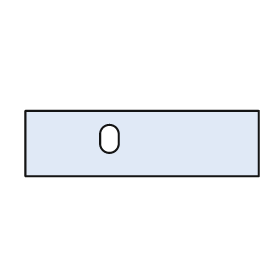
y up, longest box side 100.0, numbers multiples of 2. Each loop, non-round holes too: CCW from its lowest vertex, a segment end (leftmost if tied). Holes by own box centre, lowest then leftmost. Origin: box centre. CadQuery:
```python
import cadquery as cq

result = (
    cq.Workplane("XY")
    .moveTo(-50.0, -14.0)
    .lineTo(50.0, -14.0)
    .lineTo(50.0, 14.0)
    .lineTo(-50.0, 14.0)
    .close()
    .moveTo(-18.0, 0.0)
    .threePointArc((-14.0, -4.0), (-10.0, 0.0))
    .lineTo(-10.0, 4.0)
    .threePointArc((-14.0, 8.0), (-18.0, 4.0))
    .close()
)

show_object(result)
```